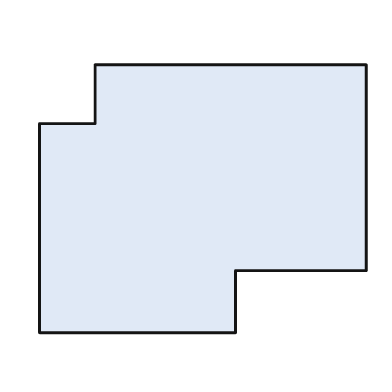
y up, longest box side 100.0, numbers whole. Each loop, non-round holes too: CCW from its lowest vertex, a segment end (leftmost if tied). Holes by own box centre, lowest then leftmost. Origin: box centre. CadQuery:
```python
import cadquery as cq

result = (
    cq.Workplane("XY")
    .moveTo(-50.0, -41.0)
    .lineTo(10.0, -41.0)
    .lineTo(10.0, -22.0)
    .lineTo(50.0, -22.0)
    .lineTo(50.0, 41.0)
    .lineTo(-33.0, 41.0)
    .lineTo(-33.0, 23.0)
    .lineTo(-50.0, 23.0)
    .close()
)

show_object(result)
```